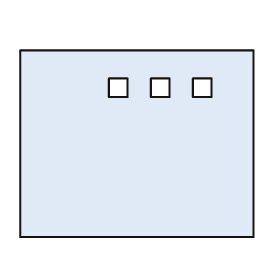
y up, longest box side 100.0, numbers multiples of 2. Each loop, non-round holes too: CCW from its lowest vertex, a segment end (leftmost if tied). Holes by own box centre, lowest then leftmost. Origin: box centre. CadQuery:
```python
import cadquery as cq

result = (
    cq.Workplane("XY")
    .moveTo(-50.0, -40.0)
    .lineTo(50.0, -40.0)
    .lineTo(50.0, 40.0)
    .lineTo(-50.0, 40.0)
    .close()
    .moveTo(-12.0, 20.0)
    .lineTo(-4.0, 20.0)
    .lineTo(-4.0, 28.0)
    .lineTo(-12.0, 28.0)
    .close()
    .moveTo(6.0, 20.0)
    .lineTo(14.0, 20.0)
    .lineTo(14.0, 28.0)
    .lineTo(6.0, 28.0)
    .close()
    .moveTo(24.0, 20.0)
    .lineTo(32.0, 20.0)
    .lineTo(32.0, 28.0)
    .lineTo(24.0, 28.0)
    .close()
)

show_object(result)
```